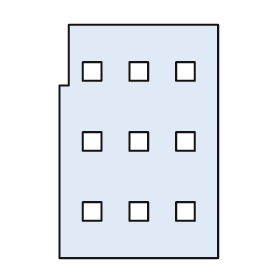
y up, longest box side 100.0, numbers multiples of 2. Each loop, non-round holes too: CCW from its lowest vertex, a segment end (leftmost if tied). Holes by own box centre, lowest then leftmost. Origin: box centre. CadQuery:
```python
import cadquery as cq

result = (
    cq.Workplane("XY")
    .moveTo(-34.0, -50.0)
    .lineTo(34.0, -50.0)
    .lineTo(34.0, 50.0)
    .lineTo(-30.0, 50.0)
    .lineTo(-30.0, 24.0)
    .lineTo(-34.0, 24.0)
    .close()
    .moveTo(-24.0, -34.0)
    .lineTo(-16.0, -34.0)
    .lineTo(-16.0, -26.0)
    .lineTo(-24.0, -26.0)
    .close()
    .moveTo(-4.0, -34.0)
    .lineTo(4.0, -34.0)
    .lineTo(4.0, -26.0)
    .lineTo(-4.0, -26.0)
    .close()
    .moveTo(16.0, -34.0)
    .lineTo(24.0, -34.0)
    .lineTo(24.0, -26.0)
    .lineTo(16.0, -26.0)
    .close()
    .moveTo(-24.0, -4.0)
    .lineTo(-16.0, -4.0)
    .lineTo(-16.0, 4.0)
    .lineTo(-24.0, 4.0)
    .close()
    .moveTo(-4.0, -4.0)
    .lineTo(4.0, -4.0)
    .lineTo(4.0, 4.0)
    .lineTo(-4.0, 4.0)
    .close()
    .moveTo(16.0, -4.0)
    .lineTo(24.0, -4.0)
    .lineTo(24.0, 4.0)
    .lineTo(16.0, 4.0)
    .close()
    .moveTo(-24.0, 26.0)
    .lineTo(-16.0, 26.0)
    .lineTo(-16.0, 34.0)
    .lineTo(-24.0, 34.0)
    .close()
    .moveTo(-4.0, 26.0)
    .lineTo(4.0, 26.0)
    .lineTo(4.0, 34.0)
    .lineTo(-4.0, 34.0)
    .close()
    .moveTo(16.0, 26.0)
    .lineTo(24.0, 26.0)
    .lineTo(24.0, 34.0)
    .lineTo(16.0, 34.0)
    .close()
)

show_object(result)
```